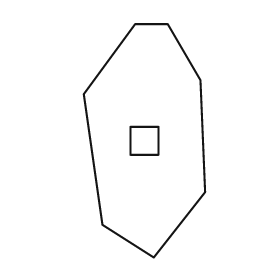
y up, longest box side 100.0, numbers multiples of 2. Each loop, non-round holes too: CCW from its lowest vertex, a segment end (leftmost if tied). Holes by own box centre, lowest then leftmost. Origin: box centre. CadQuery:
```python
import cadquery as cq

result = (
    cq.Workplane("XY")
    .moveTo(4.0, -50.0)
    .lineTo(26.0, -22.0)
    .lineTo(24.0, 26.0)
    .lineTo(10.0, 50.0)
    .lineTo(-4.0, 50.0)
    .lineTo(-26.0, 20.0)
    .lineTo(-18.0, -36.0)
    .close()
    .moveTo(-6.0, -6.0)
    .lineTo(6.0, -6.0)
    .lineTo(6.0, 6.0)
    .lineTo(-6.0, 6.0)
    .close()
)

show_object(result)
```